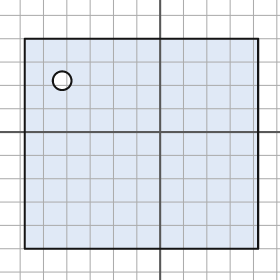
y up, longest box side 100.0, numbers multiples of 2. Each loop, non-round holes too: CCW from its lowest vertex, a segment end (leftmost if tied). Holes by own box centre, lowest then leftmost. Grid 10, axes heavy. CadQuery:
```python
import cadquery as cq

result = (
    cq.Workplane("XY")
    .moveTo(-58.0, -50.0)
    .lineTo(42.0, -50.0)
    .lineTo(42.0, 40.0)
    .lineTo(-58.0, 40.0)
    .close()
    .moveTo(-42.0, 22.0)
    .circle(4.0)
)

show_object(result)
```